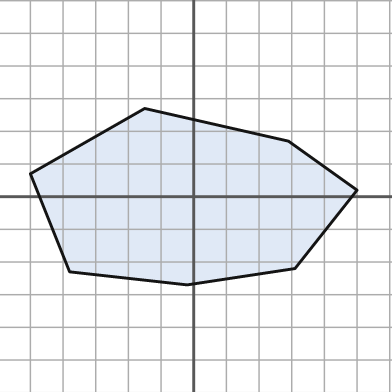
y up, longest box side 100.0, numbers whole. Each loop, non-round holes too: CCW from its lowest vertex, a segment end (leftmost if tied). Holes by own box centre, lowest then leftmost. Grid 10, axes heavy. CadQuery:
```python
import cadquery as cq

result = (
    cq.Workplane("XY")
    .moveTo(-2.0, -27.0)
    .lineTo(31.0, -22.0)
    .lineTo(50.0, 2.0)
    .lineTo(29.0, 17.0)
    .lineTo(-15.0, 27.0)
    .lineTo(-50.0, 7.0)
    .lineTo(-38.0, -23.0)
    .close()
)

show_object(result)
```